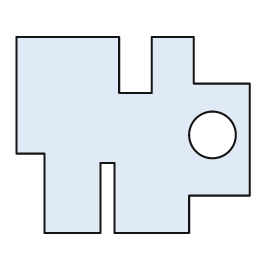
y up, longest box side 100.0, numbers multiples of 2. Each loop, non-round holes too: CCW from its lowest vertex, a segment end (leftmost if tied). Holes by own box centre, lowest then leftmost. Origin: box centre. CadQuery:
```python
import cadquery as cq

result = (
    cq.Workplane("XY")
    .moveTo(-38.0, -42.0)
    .lineTo(-14.0, -42.0)
    .lineTo(-14.0, -12.0)
    .lineTo(-8.0, -12.0)
    .lineTo(-8.0, -42.0)
    .lineTo(24.0, -42.0)
    .lineTo(24.0, -26.0)
    .lineTo(50.0, -26.0)
    .lineTo(50.0, 22.0)
    .lineTo(26.0, 22.0)
    .lineTo(26.0, 42.0)
    .lineTo(8.0, 42.0)
    .lineTo(8.0, 18.0)
    .lineTo(-6.0, 18.0)
    .lineTo(-6.0, 42.0)
    .lineTo(-50.0, 42.0)
    .lineTo(-50.0, -8.0)
    .lineTo(-38.0, -8.0)
    .close()
    .moveTo(34.0, 0.0)
    .circle(10.0)
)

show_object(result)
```